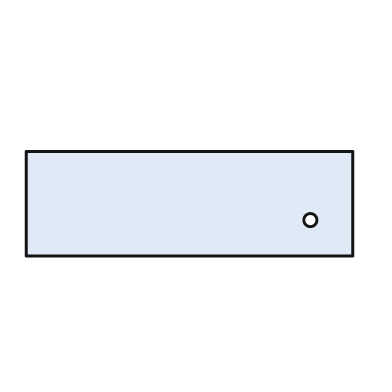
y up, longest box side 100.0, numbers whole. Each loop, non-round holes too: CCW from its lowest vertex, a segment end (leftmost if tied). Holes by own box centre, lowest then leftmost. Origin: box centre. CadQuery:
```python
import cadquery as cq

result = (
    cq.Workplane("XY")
    .moveTo(-50.0, -16.0)
    .lineTo(50.0, -16.0)
    .lineTo(50.0, 16.0)
    .lineTo(-50.0, 16.0)
    .close()
    .moveTo(37.0, -5.0)
    .circle(2.0)
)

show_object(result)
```